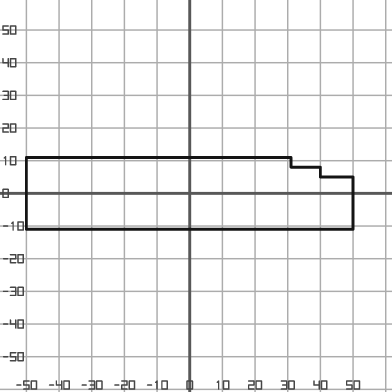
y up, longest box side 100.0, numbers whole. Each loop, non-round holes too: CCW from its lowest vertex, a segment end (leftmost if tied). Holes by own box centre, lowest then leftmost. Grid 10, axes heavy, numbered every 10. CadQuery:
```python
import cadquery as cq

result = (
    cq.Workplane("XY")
    .moveTo(-50.0, -11.0)
    .lineTo(50.0, -11.0)
    .lineTo(50.0, 5.0)
    .lineTo(40.0, 5.0)
    .lineTo(40.0, 8.0)
    .lineTo(31.0, 8.0)
    .lineTo(31.0, 11.0)
    .lineTo(-50.0, 11.0)
    .close()
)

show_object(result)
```